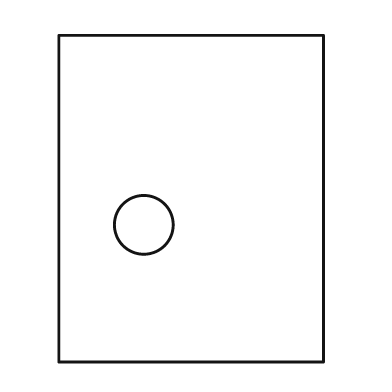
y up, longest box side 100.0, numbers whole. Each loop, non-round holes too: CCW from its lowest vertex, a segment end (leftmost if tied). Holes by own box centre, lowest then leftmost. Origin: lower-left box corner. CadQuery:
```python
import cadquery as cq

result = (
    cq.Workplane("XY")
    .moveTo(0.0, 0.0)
    .lineTo(81.0, 0.0)
    .lineTo(81.0, 100.0)
    .lineTo(0.0, 100.0)
    .close()
    .moveTo(26.0, 42.0)
    .circle(9.0)
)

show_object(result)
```